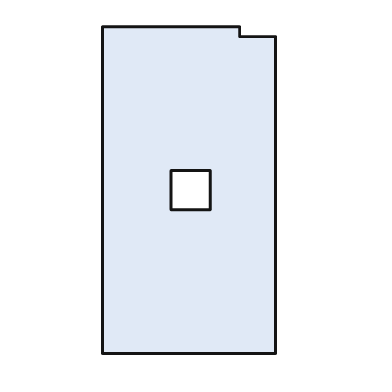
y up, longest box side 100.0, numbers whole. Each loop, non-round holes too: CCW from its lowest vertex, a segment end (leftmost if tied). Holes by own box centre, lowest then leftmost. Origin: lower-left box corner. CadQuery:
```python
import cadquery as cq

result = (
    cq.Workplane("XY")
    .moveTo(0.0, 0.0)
    .lineTo(53.0, 0.0)
    .lineTo(53.0, 97.0)
    .lineTo(42.0, 97.0)
    .lineTo(42.0, 100.0)
    .lineTo(0.0, 100.0)
    .close()
    .moveTo(21.0, 44.0)
    .lineTo(33.0, 44.0)
    .lineTo(33.0, 56.0)
    .lineTo(21.0, 56.0)
    .close()
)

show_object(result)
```